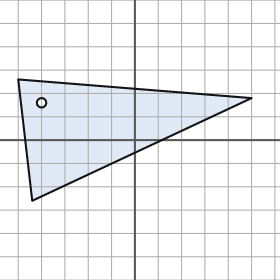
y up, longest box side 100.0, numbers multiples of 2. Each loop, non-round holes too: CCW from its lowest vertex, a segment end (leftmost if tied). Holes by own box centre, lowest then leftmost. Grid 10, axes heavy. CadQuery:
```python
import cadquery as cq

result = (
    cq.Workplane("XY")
    .moveTo(-44.0, -26.0)
    .lineTo(50.0, 18.0)
    .lineTo(-50.0, 26.0)
    .close()
    .moveTo(-40.0, 16.0)
    .circle(2.0)
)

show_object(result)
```